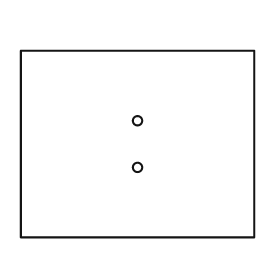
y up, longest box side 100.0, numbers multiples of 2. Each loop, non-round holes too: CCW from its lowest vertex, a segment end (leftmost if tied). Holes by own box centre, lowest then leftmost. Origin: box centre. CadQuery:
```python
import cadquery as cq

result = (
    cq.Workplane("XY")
    .moveTo(-50.0, -40.0)
    .lineTo(50.0, -40.0)
    .lineTo(50.0, 40.0)
    .lineTo(-50.0, 40.0)
    .close()
    .moveTo(0.0, -10.0)
    .circle(2.0)
    .moveTo(0.0, 10.0)
    .circle(2.0)
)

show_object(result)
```